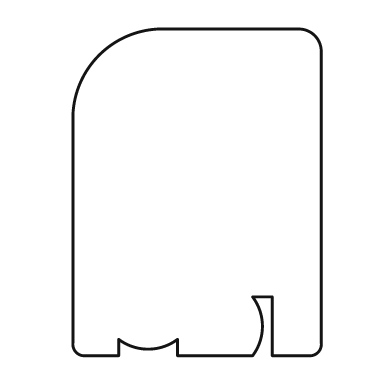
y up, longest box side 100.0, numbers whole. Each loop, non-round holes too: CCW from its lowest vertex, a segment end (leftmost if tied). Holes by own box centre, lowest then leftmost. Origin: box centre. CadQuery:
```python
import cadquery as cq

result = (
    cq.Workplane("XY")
    .moveTo(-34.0, -50.0)
    .lineTo(-24.0, -50.0)
    .lineTo(-24.0, -45.0)
    .threePointArc((-15.0, -48.0), (-6.0, -45.0))
    .lineTo(-6.0, -50.0)
    .lineTo(17.0, -50.0)
    .threePointArc((20.0, -41.0), (17.0, -32.0))
    .lineTo(23.0, -32.0)
    .lineTo(23.0, -50.0)
    .lineTo(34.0, -50.0)
    .threePointArc((37.0, -49.0), (38.0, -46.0))
    .lineTo(38.0, 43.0)
    .threePointArc((36.0, 48.0), (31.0, 50.0))
    .lineTo(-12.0, 50.0)
    .threePointArc((-30.0, 42.0), (-38.0, 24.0))
    .lineTo(-38.0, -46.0)
    .threePointArc((-37.0, -49.0), (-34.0, -50.0))
    .close()
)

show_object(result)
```